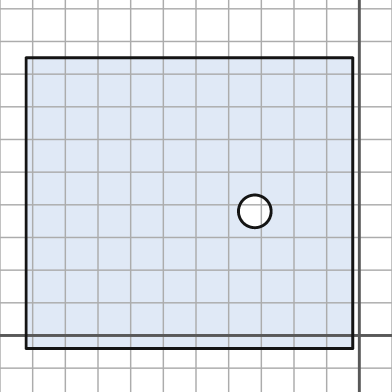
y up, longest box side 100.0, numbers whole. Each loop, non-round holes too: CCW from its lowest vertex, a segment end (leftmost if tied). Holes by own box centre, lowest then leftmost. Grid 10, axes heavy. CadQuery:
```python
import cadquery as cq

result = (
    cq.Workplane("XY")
    .moveTo(-102.0, -4.0)
    .lineTo(-2.0, -4.0)
    .lineTo(-2.0, 85.0)
    .lineTo(-102.0, 85.0)
    .close()
    .moveTo(-32.0, 38.0)
    .circle(5.0)
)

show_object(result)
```